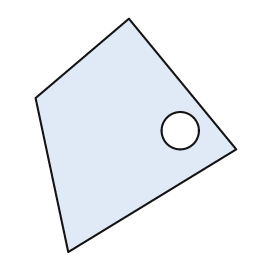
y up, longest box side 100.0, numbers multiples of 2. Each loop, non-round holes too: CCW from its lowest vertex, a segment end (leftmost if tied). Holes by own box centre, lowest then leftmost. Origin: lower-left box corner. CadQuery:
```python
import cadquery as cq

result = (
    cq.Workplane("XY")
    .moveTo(14.0, 0.0)
    .lineTo(86.0, 44.0)
    .lineTo(40.0, 100.0)
    .lineTo(0.0, 66.0)
    .close()
    .moveTo(62.0, 52.0)
    .circle(8.0)
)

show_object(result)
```